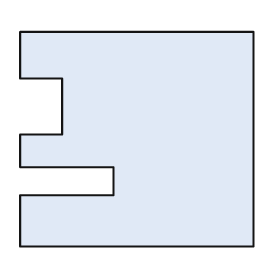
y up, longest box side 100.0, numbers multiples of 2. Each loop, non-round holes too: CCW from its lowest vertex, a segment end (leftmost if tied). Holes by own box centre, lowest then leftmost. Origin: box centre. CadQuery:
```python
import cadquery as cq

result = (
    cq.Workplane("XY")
    .moveTo(-50.0, -46.0)
    .lineTo(50.0, -46.0)
    .lineTo(50.0, 46.0)
    .lineTo(-50.0, 46.0)
    .lineTo(-50.0, 26.0)
    .lineTo(-32.0, 26.0)
    .lineTo(-32.0, 2.0)
    .lineTo(-50.0, 2.0)
    .lineTo(-50.0, -12.0)
    .lineTo(-10.0, -12.0)
    .lineTo(-10.0, -24.0)
    .lineTo(-50.0, -24.0)
    .close()
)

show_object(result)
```